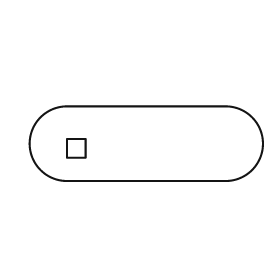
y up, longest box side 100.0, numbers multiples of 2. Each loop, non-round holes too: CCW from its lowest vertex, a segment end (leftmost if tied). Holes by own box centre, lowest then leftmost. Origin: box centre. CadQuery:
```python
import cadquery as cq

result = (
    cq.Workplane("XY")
    .moveTo(-34.0, -16.0)
    .lineTo(34.0, -16.0)
    .threePointArc((50.0, 0.0), (34.0, 16.0))
    .lineTo(-34.0, 16.0)
    .threePointArc((-50.0, 0.0), (-34.0, -16.0))
    .close()
    .moveTo(-34.0, -6.0)
    .lineTo(-26.0, -6.0)
    .lineTo(-26.0, 2.0)
    .lineTo(-34.0, 2.0)
    .close()
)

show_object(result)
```